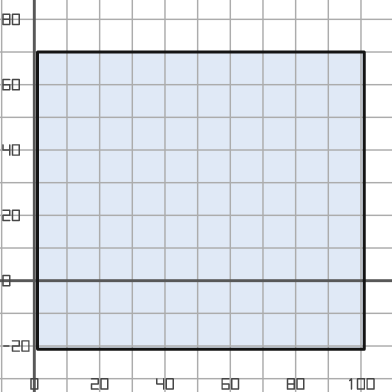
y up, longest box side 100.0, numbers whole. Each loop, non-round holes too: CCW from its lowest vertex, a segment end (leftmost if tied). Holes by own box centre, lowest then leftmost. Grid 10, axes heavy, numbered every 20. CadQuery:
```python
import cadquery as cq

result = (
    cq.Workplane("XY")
    .moveTo(1.0, -21.0)
    .lineTo(101.0, -21.0)
    .lineTo(101.0, 70.0)
    .lineTo(1.0, 70.0)
    .close()
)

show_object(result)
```